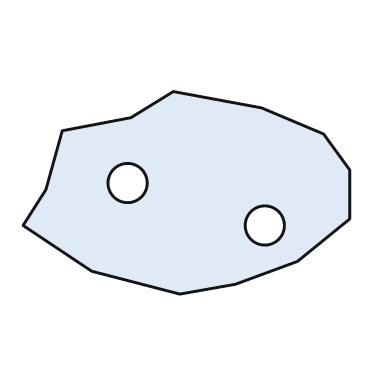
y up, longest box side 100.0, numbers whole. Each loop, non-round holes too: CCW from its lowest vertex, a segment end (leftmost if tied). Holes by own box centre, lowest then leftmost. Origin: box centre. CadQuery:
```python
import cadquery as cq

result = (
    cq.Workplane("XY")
    .moveTo(-2.0, -31.0)
    .lineTo(15.0, -28.0)
    .lineTo(34.0, -21.0)
    .lineTo(50.0, -8.0)
    .lineTo(50.0, 7.0)
    .lineTo(42.0, 18.0)
    .lineTo(23.0, 26.0)
    .lineTo(-4.0, 31.0)
    .lineTo(-17.0, 23.0)
    .lineTo(-38.0, 19.0)
    .lineTo(-43.0, 1.0)
    .lineTo(-50.0, -10.0)
    .lineTo(-29.0, -24.0)
    .close()
    .moveTo(24.0, -10.0)
    .circle(6.0)
    .moveTo(-18.0, 3.0)
    .circle(6.0)
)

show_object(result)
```